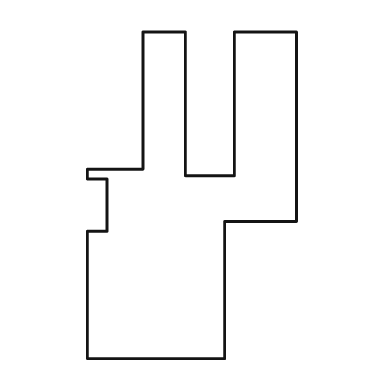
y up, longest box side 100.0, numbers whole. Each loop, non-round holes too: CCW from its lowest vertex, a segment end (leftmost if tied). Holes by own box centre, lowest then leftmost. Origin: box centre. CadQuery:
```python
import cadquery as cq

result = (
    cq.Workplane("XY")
    .moveTo(-32.0, -50.0)
    .lineTo(10.0, -50.0)
    .lineTo(10.0, -8.0)
    .lineTo(32.0, -8.0)
    .lineTo(32.0, 50.0)
    .lineTo(13.0, 50.0)
    .lineTo(13.0, 6.0)
    .lineTo(-2.0, 6.0)
    .lineTo(-2.0, 50.0)
    .lineTo(-15.0, 50.0)
    .lineTo(-15.0, 8.0)
    .lineTo(-32.0, 8.0)
    .lineTo(-32.0, 5.0)
    .lineTo(-26.0, 5.0)
    .lineTo(-26.0, -11.0)
    .lineTo(-32.0, -11.0)
    .close()
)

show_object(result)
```